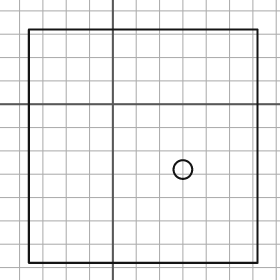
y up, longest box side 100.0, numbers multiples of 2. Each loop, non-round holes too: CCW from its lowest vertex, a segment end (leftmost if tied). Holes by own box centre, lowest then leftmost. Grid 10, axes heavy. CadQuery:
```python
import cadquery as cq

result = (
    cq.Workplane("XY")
    .moveTo(-36.0, -68.0)
    .lineTo(62.0, -68.0)
    .lineTo(62.0, 32.0)
    .lineTo(-36.0, 32.0)
    .close()
    .moveTo(30.0, -28.0)
    .circle(4.0)
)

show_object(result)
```